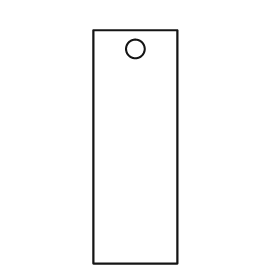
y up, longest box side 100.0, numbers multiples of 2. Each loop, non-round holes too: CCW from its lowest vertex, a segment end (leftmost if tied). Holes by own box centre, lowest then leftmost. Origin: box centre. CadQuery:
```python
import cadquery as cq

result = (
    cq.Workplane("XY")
    .moveTo(-18.0, -50.0)
    .lineTo(18.0, -50.0)
    .lineTo(18.0, 50.0)
    .lineTo(-18.0, 50.0)
    .close()
    .moveTo(0.0, 42.0)
    .circle(4.0)
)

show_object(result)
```